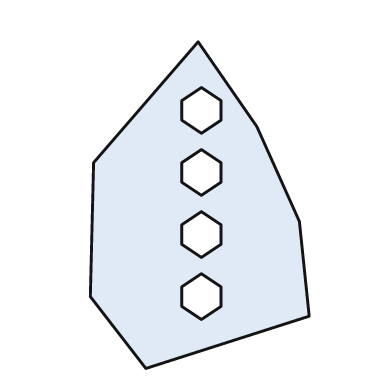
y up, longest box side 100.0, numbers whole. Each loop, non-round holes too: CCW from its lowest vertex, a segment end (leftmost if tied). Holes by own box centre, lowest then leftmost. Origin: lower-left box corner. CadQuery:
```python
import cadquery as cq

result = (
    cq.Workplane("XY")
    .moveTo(17.0, 0.0)
    .lineTo(67.0, 16.0)
    .lineTo(64.0, 45.0)
    .lineTo(51.0, 74.0)
    .lineTo(33.0, 100.0)
    .lineTo(1.0, 63.0)
    .lineTo(0.0, 22.0)
    .close()
    .moveTo(34.0, 15.0)
    .lineTo(40.0, 19.0)
    .lineTo(40.0, 25.0)
    .lineTo(34.0, 29.0)
    .lineTo(28.0, 25.0)
    .lineTo(28.0, 19.0)
    .close()
    .moveTo(34.0, 34.0)
    .lineTo(40.0, 38.0)
    .lineTo(40.0, 44.0)
    .lineTo(34.0, 48.0)
    .lineTo(28.0, 44.0)
    .lineTo(28.0, 38.0)
    .close()
    .moveTo(34.0, 53.0)
    .lineTo(40.0, 57.0)
    .lineTo(40.0, 63.0)
    .lineTo(34.0, 67.0)
    .lineTo(28.0, 63.0)
    .lineTo(28.0, 57.0)
    .close()
    .moveTo(34.0, 72.0)
    .lineTo(40.0, 76.0)
    .lineTo(40.0, 82.0)
    .lineTo(34.0, 86.0)
    .lineTo(28.0, 82.0)
    .lineTo(28.0, 76.0)
    .close()
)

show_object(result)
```